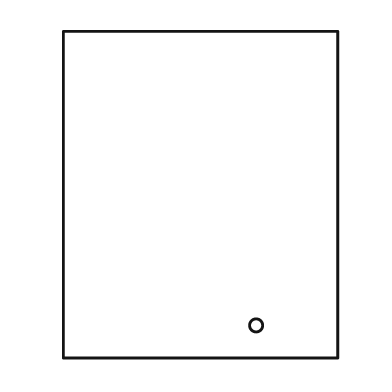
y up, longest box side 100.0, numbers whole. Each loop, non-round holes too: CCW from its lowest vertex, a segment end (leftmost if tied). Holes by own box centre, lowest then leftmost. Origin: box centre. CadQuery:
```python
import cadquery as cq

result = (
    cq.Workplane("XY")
    .moveTo(-42.0, -50.0)
    .lineTo(42.0, -50.0)
    .lineTo(42.0, 50.0)
    .lineTo(-42.0, 50.0)
    .close()
    .moveTo(17.0, -40.0)
    .circle(2.0)
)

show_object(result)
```